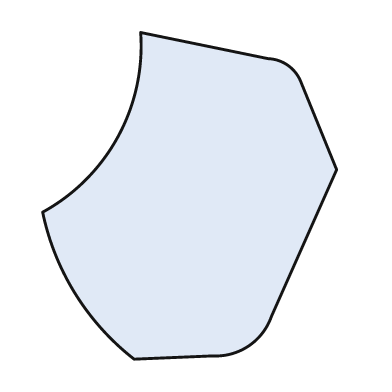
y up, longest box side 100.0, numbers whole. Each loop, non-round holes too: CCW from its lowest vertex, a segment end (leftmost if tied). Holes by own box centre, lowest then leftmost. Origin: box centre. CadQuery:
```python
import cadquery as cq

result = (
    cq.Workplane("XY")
    .moveTo(-17.0, -50.0)
    .lineTo(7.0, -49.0)
    .threePointArc((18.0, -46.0), (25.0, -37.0))
    .lineTo(45.0, 8.0)
    .lineTo(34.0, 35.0)
    .threePointArc((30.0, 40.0), (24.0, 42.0))
    .lineTo(-15.0, 50.0)
    .threePointArc((-22.0, 18.0), (-45.0, -5.0))
    .threePointArc((-35.0, -30.0), (-17.0, -50.0))
    .close()
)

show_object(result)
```